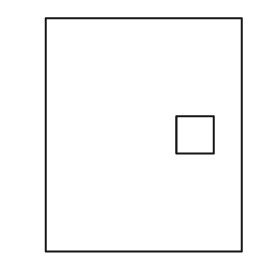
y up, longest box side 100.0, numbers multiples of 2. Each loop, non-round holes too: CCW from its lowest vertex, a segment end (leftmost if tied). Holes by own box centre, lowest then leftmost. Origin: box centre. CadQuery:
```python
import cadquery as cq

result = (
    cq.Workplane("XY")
    .moveTo(-42.0, -50.0)
    .lineTo(42.0, -50.0)
    .lineTo(42.0, 50.0)
    .lineTo(-42.0, 50.0)
    .close()
    .moveTo(14.0, -8.0)
    .lineTo(30.0, -8.0)
    .lineTo(30.0, 8.0)
    .lineTo(14.0, 8.0)
    .close()
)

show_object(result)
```